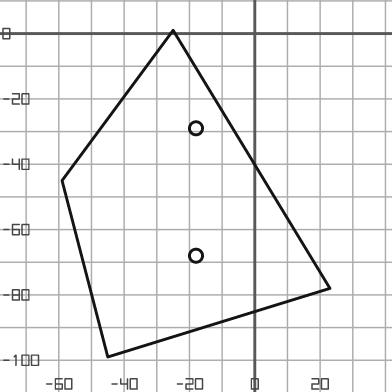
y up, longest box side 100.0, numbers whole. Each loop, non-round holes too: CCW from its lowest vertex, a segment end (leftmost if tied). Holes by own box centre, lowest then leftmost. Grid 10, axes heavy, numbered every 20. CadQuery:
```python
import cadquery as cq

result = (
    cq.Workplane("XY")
    .moveTo(-45.0, -99.0)
    .lineTo(23.0, -78.0)
    .lineTo(-25.0, 1.0)
    .lineTo(-59.0, -45.0)
    .close()
    .moveTo(-18.0, -68.0)
    .circle(2.0)
    .moveTo(-18.0, -29.0)
    .circle(2.0)
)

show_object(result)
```